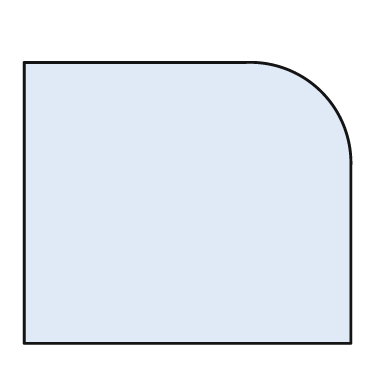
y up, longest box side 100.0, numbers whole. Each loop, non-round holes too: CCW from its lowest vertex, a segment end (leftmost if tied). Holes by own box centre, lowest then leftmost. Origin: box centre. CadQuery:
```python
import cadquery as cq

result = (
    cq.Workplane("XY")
    .moveTo(-50.0, -43.0)
    .lineTo(50.0, -43.0)
    .lineTo(50.0, 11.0)
    .threePointArc((41.0, 34.0), (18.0, 43.0))
    .lineTo(-50.0, 43.0)
    .close()
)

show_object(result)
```